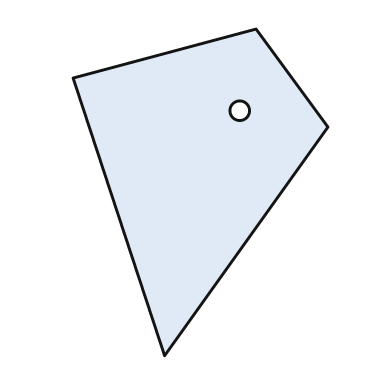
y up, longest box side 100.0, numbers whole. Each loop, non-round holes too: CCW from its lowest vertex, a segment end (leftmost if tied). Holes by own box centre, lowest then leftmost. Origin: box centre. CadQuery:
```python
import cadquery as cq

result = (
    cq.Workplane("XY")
    .moveTo(-11.0, -50.0)
    .lineTo(39.0, 20.0)
    .lineTo(17.0, 50.0)
    .lineTo(-39.0, 35.0)
    .close()
    .moveTo(12.0, 25.0)
    .circle(3.0)
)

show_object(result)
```